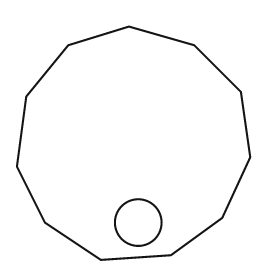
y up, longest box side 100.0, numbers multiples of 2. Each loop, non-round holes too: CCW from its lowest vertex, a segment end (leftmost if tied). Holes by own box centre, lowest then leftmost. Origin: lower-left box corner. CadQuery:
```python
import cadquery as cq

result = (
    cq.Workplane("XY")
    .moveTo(36.0, 0.0)
    .lineTo(66.0, 2.0)
    .lineTo(88.0, 18.0)
    .lineTo(100.0, 44.0)
    .lineTo(96.0, 72.0)
    .lineTo(76.0, 92.0)
    .lineTo(48.0, 100.0)
    .lineTo(22.0, 92.0)
    .lineTo(4.0, 70.0)
    .lineTo(0.0, 40.0)
    .lineTo(12.0, 16.0)
    .close()
    .moveTo(52.0, 16.0)
    .circle(10.0)
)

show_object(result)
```